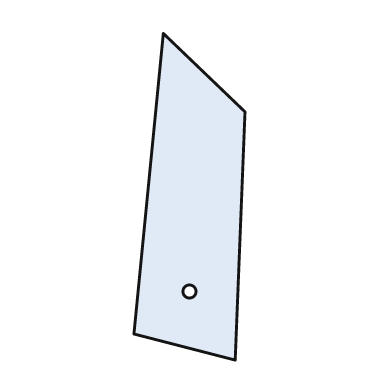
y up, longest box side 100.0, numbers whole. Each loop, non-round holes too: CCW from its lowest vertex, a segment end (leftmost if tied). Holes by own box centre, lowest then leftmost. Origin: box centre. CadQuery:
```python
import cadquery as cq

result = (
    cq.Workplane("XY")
    .moveTo(14.0, -50.0)
    .lineTo(17.0, 26.0)
    .lineTo(-8.0, 50.0)
    .lineTo(-17.0, -42.0)
    .close()
    .moveTo(0.0, -29.0)
    .circle(2.0)
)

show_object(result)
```